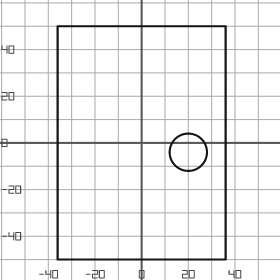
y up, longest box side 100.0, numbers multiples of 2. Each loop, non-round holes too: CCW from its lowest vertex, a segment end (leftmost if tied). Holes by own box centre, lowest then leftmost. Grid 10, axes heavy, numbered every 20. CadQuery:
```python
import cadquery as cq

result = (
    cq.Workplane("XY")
    .moveTo(-36.0, -50.0)
    .lineTo(36.0, -50.0)
    .lineTo(36.0, 50.0)
    .lineTo(-36.0, 50.0)
    .close()
    .moveTo(20.0, -4.0)
    .circle(8.0)
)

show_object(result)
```